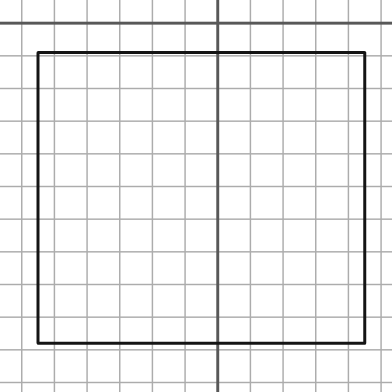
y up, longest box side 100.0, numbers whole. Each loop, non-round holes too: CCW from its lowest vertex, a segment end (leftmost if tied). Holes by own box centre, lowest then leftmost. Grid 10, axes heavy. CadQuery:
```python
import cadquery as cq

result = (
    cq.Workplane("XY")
    .moveTo(-55.0, -98.0)
    .lineTo(45.0, -98.0)
    .lineTo(45.0, -9.0)
    .lineTo(-55.0, -9.0)
    .close()
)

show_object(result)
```